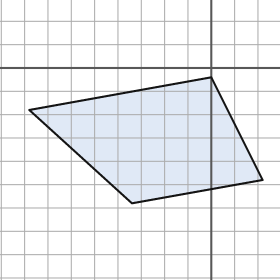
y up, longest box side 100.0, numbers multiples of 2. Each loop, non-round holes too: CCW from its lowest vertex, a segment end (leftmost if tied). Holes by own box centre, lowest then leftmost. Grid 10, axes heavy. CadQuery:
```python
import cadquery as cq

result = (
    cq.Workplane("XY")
    .moveTo(-34.0, -58.0)
    .lineTo(22.0, -48.0)
    .lineTo(0.0, -4.0)
    .lineTo(-78.0, -18.0)
    .close()
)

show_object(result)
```